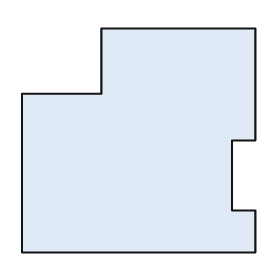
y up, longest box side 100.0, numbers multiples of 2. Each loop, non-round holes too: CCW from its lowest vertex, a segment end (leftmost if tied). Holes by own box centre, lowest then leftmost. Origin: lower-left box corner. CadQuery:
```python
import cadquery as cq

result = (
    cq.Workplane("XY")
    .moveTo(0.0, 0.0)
    .lineTo(100.0, 0.0)
    .lineTo(100.0, 18.0)
    .lineTo(90.0, 18.0)
    .lineTo(90.0, 48.0)
    .lineTo(100.0, 48.0)
    .lineTo(100.0, 96.0)
    .lineTo(34.0, 96.0)
    .lineTo(34.0, 68.0)
    .lineTo(0.0, 68.0)
    .close()
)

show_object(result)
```